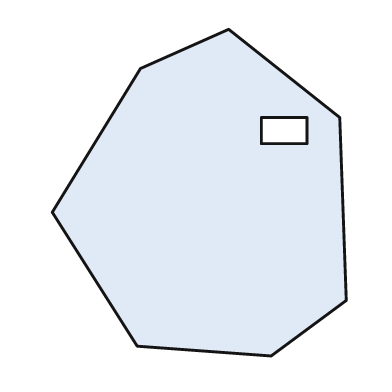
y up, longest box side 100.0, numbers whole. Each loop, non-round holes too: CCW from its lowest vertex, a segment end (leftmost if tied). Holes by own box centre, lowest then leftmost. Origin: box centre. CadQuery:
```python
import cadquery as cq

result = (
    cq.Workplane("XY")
    .moveTo(22.0, -50.0)
    .lineTo(45.0, -33.0)
    .lineTo(43.0, 23.0)
    .lineTo(9.0, 50.0)
    .lineTo(-18.0, 38.0)
    .lineTo(-45.0, -6.0)
    .lineTo(-19.0, -47.0)
    .close()
    .moveTo(19.0, 15.0)
    .lineTo(33.0, 15.0)
    .lineTo(33.0, 23.0)
    .lineTo(19.0, 23.0)
    .close()
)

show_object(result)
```